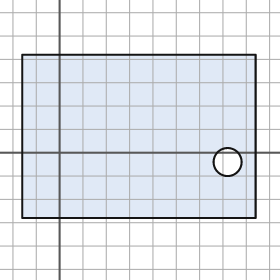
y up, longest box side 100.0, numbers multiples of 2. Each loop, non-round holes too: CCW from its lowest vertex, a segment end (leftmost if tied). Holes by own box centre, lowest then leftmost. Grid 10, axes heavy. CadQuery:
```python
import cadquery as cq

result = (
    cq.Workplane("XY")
    .moveTo(-16.0, -28.0)
    .lineTo(84.0, -28.0)
    .lineTo(84.0, 42.0)
    .lineTo(-16.0, 42.0)
    .close()
    .moveTo(72.0, -4.0)
    .circle(6.0)
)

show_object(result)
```